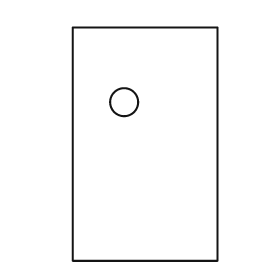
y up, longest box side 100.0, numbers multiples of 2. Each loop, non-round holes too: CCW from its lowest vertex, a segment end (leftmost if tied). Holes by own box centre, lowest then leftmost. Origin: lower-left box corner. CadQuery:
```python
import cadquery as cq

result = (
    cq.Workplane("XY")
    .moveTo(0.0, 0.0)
    .lineTo(62.0, 0.0)
    .lineTo(62.0, 100.0)
    .lineTo(0.0, 100.0)
    .close()
    .moveTo(22.0, 68.0)
    .circle(6.0)
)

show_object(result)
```